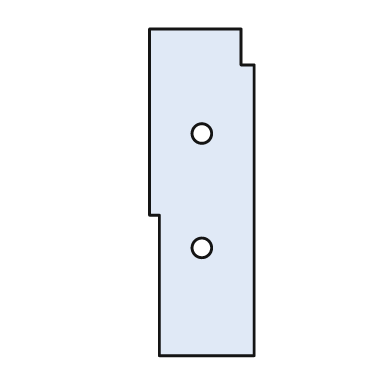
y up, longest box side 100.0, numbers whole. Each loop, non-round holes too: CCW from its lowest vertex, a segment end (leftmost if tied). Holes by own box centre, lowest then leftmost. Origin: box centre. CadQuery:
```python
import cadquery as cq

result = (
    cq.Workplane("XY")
    .moveTo(-13.0, -50.0)
    .lineTo(16.0, -50.0)
    .lineTo(16.0, 39.0)
    .lineTo(12.0, 39.0)
    .lineTo(12.0, 50.0)
    .lineTo(-16.0, 50.0)
    .lineTo(-16.0, -7.0)
    .lineTo(-13.0, -7.0)
    .close()
    .moveTo(0.0, -17.0)
    .circle(3.0)
    .moveTo(0.0, 18.0)
    .circle(3.0)
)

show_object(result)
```